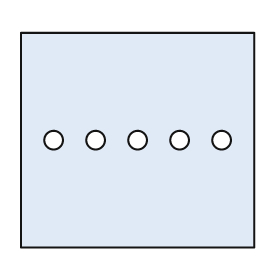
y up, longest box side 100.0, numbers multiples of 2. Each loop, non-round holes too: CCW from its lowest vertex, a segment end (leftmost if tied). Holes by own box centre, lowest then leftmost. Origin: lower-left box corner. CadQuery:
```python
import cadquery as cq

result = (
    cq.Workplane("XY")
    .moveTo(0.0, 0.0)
    .lineTo(100.0, 0.0)
    .lineTo(100.0, 92.0)
    .lineTo(0.0, 92.0)
    .close()
    .moveTo(14.0, 46.0)
    .circle(4.0)
    .moveTo(32.0, 46.0)
    .circle(4.0)
    .moveTo(50.0, 46.0)
    .circle(4.0)
    .moveTo(68.0, 46.0)
    .circle(4.0)
    .moveTo(86.0, 46.0)
    .circle(4.0)
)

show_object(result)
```